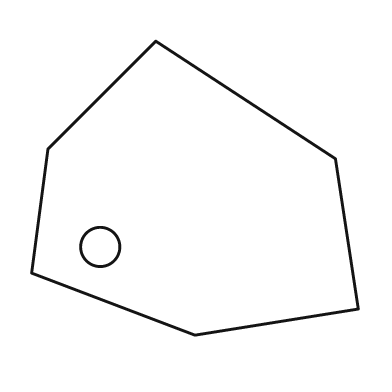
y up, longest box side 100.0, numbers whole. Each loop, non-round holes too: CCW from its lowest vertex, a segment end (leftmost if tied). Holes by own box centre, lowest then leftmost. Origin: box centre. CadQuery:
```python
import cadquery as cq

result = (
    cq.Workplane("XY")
    .moveTo(0.0, -45.0)
    .lineTo(50.0, -37.0)
    .lineTo(43.0, 9.0)
    .lineTo(-12.0, 45.0)
    .lineTo(-45.0, 12.0)
    .lineTo(-50.0, -26.0)
    .close()
    .moveTo(-29.0, -18.0)
    .circle(6.0)
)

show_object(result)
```